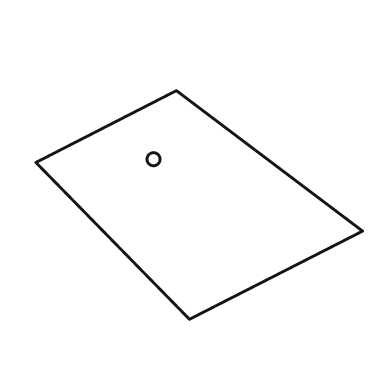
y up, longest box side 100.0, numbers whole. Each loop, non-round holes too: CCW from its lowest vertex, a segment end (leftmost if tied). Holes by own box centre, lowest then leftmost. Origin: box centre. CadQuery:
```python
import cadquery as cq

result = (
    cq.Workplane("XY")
    .moveTo(-3.0, -35.0)
    .lineTo(50.0, -8.0)
    .lineTo(-7.0, 35.0)
    .lineTo(-50.0, 13.0)
    .close()
    .moveTo(-14.0, 14.0)
    .circle(2.0)
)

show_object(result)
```